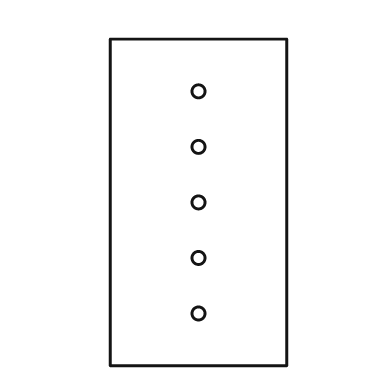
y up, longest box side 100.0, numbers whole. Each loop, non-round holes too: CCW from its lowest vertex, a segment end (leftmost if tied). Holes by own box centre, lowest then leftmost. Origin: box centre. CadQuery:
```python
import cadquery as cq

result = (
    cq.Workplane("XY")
    .moveTo(-27.0, -50.0)
    .lineTo(27.0, -50.0)
    .lineTo(27.0, 50.0)
    .lineTo(-27.0, 50.0)
    .close()
    .moveTo(0.0, -34.0)
    .circle(2.0)
    .moveTo(0.0, -17.0)
    .circle(2.0)
    .moveTo(0.0, 0.0)
    .circle(2.0)
    .moveTo(0.0, 17.0)
    .circle(2.0)
    .moveTo(0.0, 34.0)
    .circle(2.0)
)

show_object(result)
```